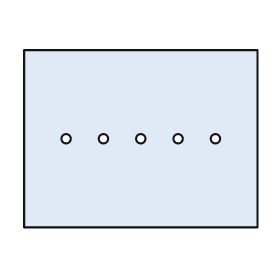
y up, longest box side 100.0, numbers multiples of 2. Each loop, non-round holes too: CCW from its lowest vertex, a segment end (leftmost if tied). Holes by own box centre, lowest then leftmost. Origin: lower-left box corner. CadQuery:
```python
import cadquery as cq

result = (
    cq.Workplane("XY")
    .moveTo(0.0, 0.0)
    .lineTo(100.0, 0.0)
    .lineTo(100.0, 76.0)
    .lineTo(0.0, 76.0)
    .close()
    .moveTo(18.0, 38.0)
    .circle(2.0)
    .moveTo(34.0, 38.0)
    .circle(2.0)
    .moveTo(50.0, 38.0)
    .circle(2.0)
    .moveTo(66.0, 38.0)
    .circle(2.0)
    .moveTo(82.0, 38.0)
    .circle(2.0)
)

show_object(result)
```